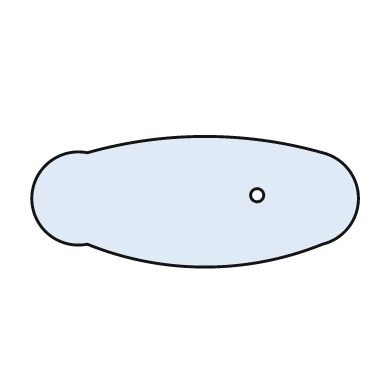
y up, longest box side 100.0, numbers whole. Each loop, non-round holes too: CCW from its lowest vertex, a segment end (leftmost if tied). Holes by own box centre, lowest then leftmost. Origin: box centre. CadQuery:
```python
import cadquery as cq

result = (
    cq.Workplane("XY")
    .moveTo(-33.0, -13.0)
    .threePointArc((3.0, -20.0), (39.0, -13.0))
    .threePointArc((50.0, 1.0), (39.0, 15.0))
    .threePointArc((3.0, 20.0), (-33.0, 15.0))
    .threePointArc((-50.0, 1.0), (-33.0, -13.0))
    .close()
    .moveTo(19.0, 2.0)
    .circle(2.0)
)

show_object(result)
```